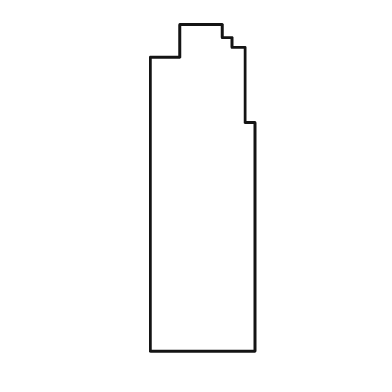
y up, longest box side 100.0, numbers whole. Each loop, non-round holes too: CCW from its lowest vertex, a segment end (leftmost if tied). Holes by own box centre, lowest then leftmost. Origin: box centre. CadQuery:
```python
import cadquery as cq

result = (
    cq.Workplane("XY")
    .moveTo(-16.0, -50.0)
    .lineTo(16.0, -50.0)
    .lineTo(16.0, 20.0)
    .lineTo(13.0, 20.0)
    .lineTo(13.0, 43.0)
    .lineTo(9.0, 43.0)
    .lineTo(9.0, 46.0)
    .lineTo(6.0, 46.0)
    .lineTo(6.0, 50.0)
    .lineTo(-7.0, 50.0)
    .lineTo(-7.0, 40.0)
    .lineTo(-16.0, 40.0)
    .close()
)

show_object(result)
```